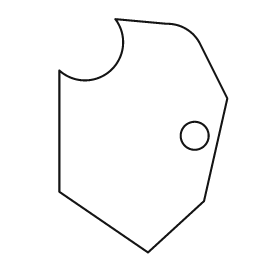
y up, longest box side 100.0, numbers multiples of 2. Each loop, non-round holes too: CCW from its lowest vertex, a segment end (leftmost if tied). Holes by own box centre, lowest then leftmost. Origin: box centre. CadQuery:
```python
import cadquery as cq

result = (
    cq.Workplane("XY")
    .moveTo(2.0, -50.0)
    .lineTo(26.0, -28.0)
    .lineTo(36.0, 16.0)
    .lineTo(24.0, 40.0)
    .threePointArc((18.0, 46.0), (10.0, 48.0))
    .lineTo(-12.0, 50.0)
    .threePointArc((-14.0, 28.0), (-36.0, 28.0))
    .lineTo(-36.0, -24.0)
    .close()
    .moveTo(22.0, 0.0)
    .circle(6.0)
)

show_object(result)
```